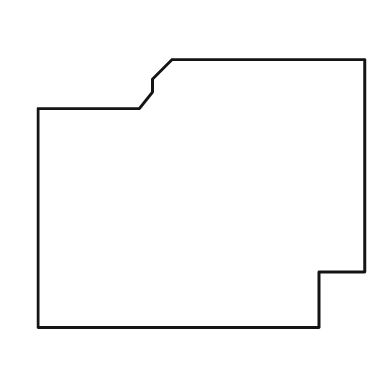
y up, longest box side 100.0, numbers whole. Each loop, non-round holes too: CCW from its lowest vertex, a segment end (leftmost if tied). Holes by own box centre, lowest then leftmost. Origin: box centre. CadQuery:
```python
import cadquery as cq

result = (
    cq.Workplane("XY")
    .moveTo(-50.0, -41.0)
    .lineTo(36.0, -41.0)
    .lineTo(36.0, -24.0)
    .lineTo(50.0, -24.0)
    .lineTo(50.0, 41.0)
    .lineTo(-9.0, 41.0)
    .lineTo(-15.0, 35.0)
    .lineTo(-15.0, 31.0)
    .lineTo(-19.0, 26.0)
    .lineTo(-50.0, 26.0)
    .close()
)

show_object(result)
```